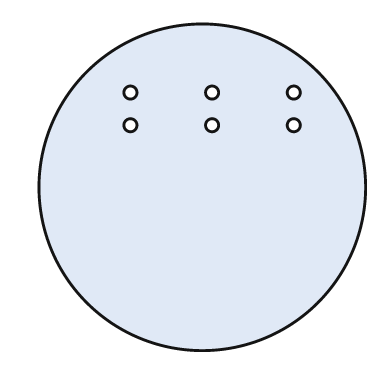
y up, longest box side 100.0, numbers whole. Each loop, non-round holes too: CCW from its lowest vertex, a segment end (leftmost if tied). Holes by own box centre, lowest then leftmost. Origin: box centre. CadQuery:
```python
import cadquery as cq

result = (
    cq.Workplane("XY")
    .moveTo(0.0, 0.0)
    .circle(50.0)
    .moveTo(-22.0, 19.0)
    .circle(2.0)
    .moveTo(3.0, 19.0)
    .circle(2.0)
    .moveTo(28.0, 19.0)
    .circle(2.0)
    .moveTo(-22.0, 29.0)
    .circle(2.0)
    .moveTo(3.0, 29.0)
    .circle(2.0)
    .moveTo(28.0, 29.0)
    .circle(2.0)
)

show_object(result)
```